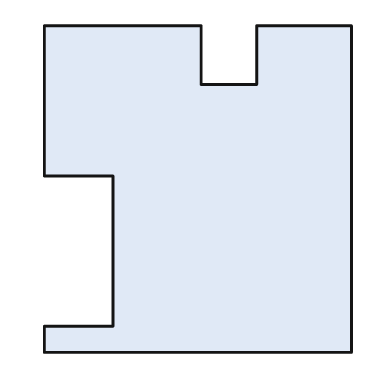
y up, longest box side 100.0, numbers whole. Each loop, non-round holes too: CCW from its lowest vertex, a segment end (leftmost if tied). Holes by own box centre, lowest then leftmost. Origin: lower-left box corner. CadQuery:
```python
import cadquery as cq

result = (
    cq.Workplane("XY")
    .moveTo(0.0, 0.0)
    .lineTo(94.0, 0.0)
    .lineTo(94.0, 100.0)
    .lineTo(65.0, 100.0)
    .lineTo(65.0, 82.0)
    .lineTo(48.0, 82.0)
    .lineTo(48.0, 100.0)
    .lineTo(0.0, 100.0)
    .lineTo(0.0, 54.0)
    .lineTo(21.0, 54.0)
    .lineTo(21.0, 8.0)
    .lineTo(0.0, 8.0)
    .close()
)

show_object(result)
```